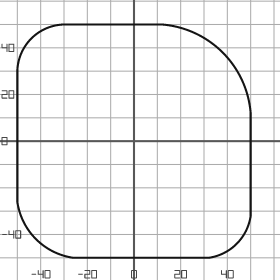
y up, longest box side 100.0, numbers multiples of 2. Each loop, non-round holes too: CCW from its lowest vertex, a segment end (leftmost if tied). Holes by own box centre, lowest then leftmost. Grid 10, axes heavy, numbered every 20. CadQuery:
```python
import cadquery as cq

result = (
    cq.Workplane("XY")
    .moveTo(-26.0, -50.0)
    .lineTo(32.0, -50.0)
    .threePointArc((44.0, -44.0), (50.0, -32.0))
    .lineTo(50.0, 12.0)
    .threePointArc((38.0, 38.0), (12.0, 50.0))
    .lineTo(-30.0, 50.0)
    .threePointArc((-44.0, 44.0), (-50.0, 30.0))
    .lineTo(-50.0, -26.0)
    .threePointArc((-42.0, -42.0), (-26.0, -50.0))
    .close()
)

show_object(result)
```